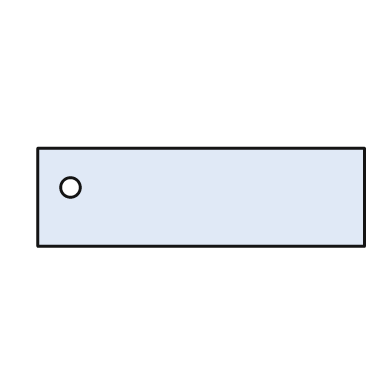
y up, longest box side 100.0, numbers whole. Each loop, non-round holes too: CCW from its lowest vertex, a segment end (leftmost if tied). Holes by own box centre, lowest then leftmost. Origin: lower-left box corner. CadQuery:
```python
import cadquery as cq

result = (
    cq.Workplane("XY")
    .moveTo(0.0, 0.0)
    .lineTo(100.0, 0.0)
    .lineTo(100.0, 30.0)
    .lineTo(0.0, 30.0)
    .close()
    .moveTo(10.0, 18.0)
    .circle(3.0)
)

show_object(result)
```